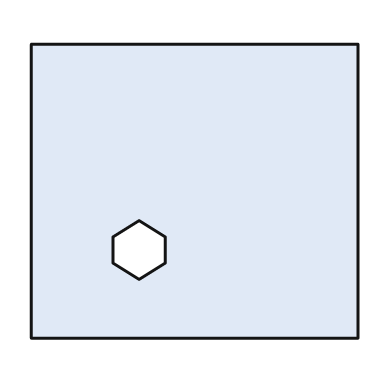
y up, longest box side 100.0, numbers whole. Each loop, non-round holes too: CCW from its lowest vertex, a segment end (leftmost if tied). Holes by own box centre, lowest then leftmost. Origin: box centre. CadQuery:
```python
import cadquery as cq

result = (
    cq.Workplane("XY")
    .moveTo(-50.0, -45.0)
    .lineTo(50.0, -45.0)
    .lineTo(50.0, 45.0)
    .lineTo(-50.0, 45.0)
    .close()
    .moveTo(-17.0, -27.0)
    .lineTo(-9.0, -22.0)
    .lineTo(-9.0, -14.0)
    .lineTo(-17.0, -9.0)
    .lineTo(-25.0, -14.0)
    .lineTo(-25.0, -22.0)
    .close()
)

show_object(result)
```